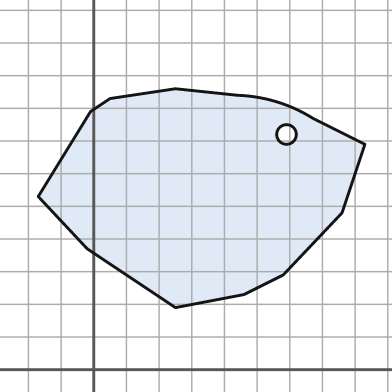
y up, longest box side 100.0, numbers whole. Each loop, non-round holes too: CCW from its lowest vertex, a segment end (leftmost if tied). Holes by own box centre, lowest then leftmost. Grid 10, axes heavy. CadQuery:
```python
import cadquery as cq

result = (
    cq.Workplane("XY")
    .moveTo(25.0, 19.0)
    .lineTo(46.0, 23.0)
    .lineTo(58.0, 29.0)
    .lineTo(76.0, 48.0)
    .lineTo(83.0, 69.0)
    .lineTo(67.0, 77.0)
    .threePointArc((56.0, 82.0), (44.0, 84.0))
    .lineTo(25.0, 86.0)
    .lineTo(5.0, 83.0)
    .lineTo(-1.0, 79.0)
    .lineTo(-17.0, 53.0)
    .lineTo(-2.0, 37.0)
    .close()
    .moveTo(59.0, 72.0)
    .circle(3.0)
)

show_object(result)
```